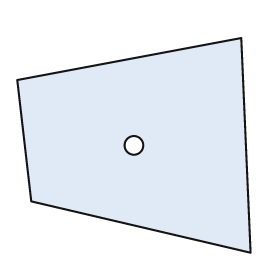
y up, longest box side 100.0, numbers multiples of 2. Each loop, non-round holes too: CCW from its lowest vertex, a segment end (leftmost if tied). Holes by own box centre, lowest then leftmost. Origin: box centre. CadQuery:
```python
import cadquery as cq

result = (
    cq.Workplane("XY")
    .moveTo(50.0, -46.0)
    .lineTo(46.0, 46.0)
    .lineTo(-50.0, 28.0)
    .lineTo(-44.0, -24.0)
    .close()
    .moveTo(0.0, 0.0)
    .circle(4.0)
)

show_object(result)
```